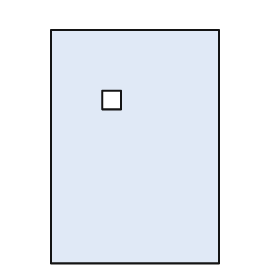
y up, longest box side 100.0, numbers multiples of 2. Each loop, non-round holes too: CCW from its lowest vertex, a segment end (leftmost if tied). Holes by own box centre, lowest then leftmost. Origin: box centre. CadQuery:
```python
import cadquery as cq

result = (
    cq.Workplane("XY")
    .moveTo(-36.0, -50.0)
    .lineTo(36.0, -50.0)
    .lineTo(36.0, 50.0)
    .lineTo(-36.0, 50.0)
    .close()
    .moveTo(-14.0, 16.0)
    .lineTo(-6.0, 16.0)
    .lineTo(-6.0, 24.0)
    .lineTo(-14.0, 24.0)
    .close()
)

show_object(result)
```